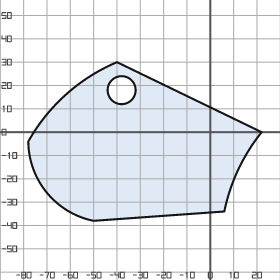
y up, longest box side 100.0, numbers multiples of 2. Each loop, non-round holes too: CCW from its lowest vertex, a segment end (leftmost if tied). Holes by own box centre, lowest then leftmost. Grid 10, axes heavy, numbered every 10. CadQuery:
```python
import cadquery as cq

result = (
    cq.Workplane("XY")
    .moveTo(-50.0, -38.0)
    .lineTo(6.0, -34.0)
    .threePointArc((12.0, -16.0), (22.0, 0.0))
    .lineTo(-40.0, 30.0)
    .threePointArc((-62.0, 16.0), (-78.0, -4.0))
    .threePointArc((-70.0, -26.0), (-50.0, -38.0))
    .close()
    .moveTo(-38.0, 18.0)
    .circle(6.0)
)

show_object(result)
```